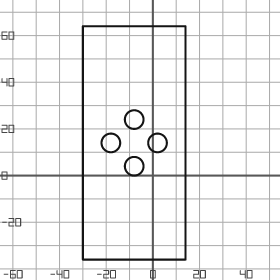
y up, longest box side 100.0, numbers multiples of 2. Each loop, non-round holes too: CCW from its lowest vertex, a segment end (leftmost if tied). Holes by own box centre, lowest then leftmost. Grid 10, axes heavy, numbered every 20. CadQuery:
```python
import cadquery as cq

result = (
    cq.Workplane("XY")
    .moveTo(-30.0, -36.0)
    .lineTo(14.0, -36.0)
    .lineTo(14.0, 64.0)
    .lineTo(-30.0, 64.0)
    .close()
    .moveTo(-8.0, 4.0)
    .circle(4.0)
    .moveTo(-18.0, 14.0)
    .circle(4.0)
    .moveTo(2.0, 14.0)
    .circle(4.0)
    .moveTo(-8.0, 24.0)
    .circle(4.0)
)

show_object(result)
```